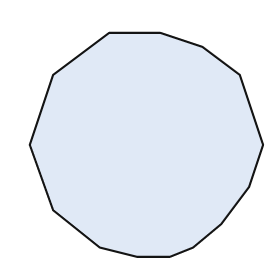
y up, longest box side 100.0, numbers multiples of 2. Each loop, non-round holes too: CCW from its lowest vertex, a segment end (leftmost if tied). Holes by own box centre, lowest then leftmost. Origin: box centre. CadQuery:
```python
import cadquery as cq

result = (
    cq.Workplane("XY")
    .moveTo(-4.0, -48.0)
    .lineTo(10.0, -48.0)
    .lineTo(20.0, -44.0)
    .lineTo(32.0, -34.0)
    .lineTo(44.0, -18.0)
    .lineTo(50.0, 0.0)
    .lineTo(40.0, 30.0)
    .lineTo(24.0, 42.0)
    .lineTo(6.0, 48.0)
    .lineTo(-16.0, 48.0)
    .lineTo(-40.0, 30.0)
    .lineTo(-50.0, 0.0)
    .lineTo(-40.0, -28.0)
    .lineTo(-20.0, -44.0)
    .close()
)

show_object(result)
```